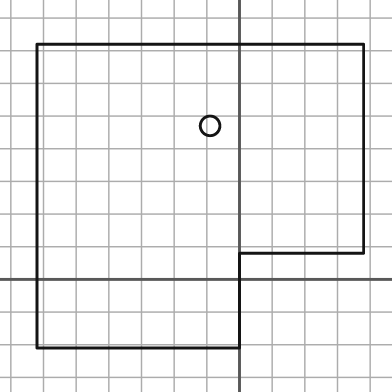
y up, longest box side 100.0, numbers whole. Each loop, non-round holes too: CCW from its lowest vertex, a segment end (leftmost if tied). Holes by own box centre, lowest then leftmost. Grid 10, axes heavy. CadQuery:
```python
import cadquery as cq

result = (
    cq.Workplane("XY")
    .moveTo(-62.0, -21.0)
    .lineTo(0.0, -21.0)
    .lineTo(0.0, 8.0)
    .lineTo(38.0, 8.0)
    .lineTo(38.0, 72.0)
    .lineTo(-62.0, 72.0)
    .close()
    .moveTo(-9.0, 47.0)
    .circle(3.0)
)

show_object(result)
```